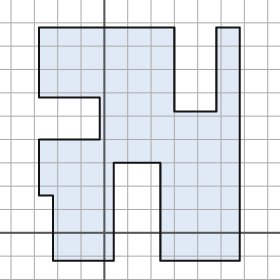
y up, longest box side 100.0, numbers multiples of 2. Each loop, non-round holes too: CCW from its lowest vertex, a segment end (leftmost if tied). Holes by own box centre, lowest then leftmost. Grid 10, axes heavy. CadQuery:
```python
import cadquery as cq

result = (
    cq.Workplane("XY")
    .moveTo(-22.0, -12.0)
    .lineTo(4.0, -12.0)
    .lineTo(4.0, 30.0)
    .lineTo(24.0, 30.0)
    .lineTo(24.0, -12.0)
    .lineTo(58.0, -12.0)
    .lineTo(58.0, 88.0)
    .lineTo(48.0, 88.0)
    .lineTo(48.0, 52.0)
    .lineTo(30.0, 52.0)
    .lineTo(30.0, 88.0)
    .lineTo(-28.0, 88.0)
    .lineTo(-28.0, 58.0)
    .lineTo(-2.0, 58.0)
    .lineTo(-2.0, 40.0)
    .lineTo(-28.0, 40.0)
    .lineTo(-28.0, 16.0)
    .lineTo(-22.0, 16.0)
    .close()
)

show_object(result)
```